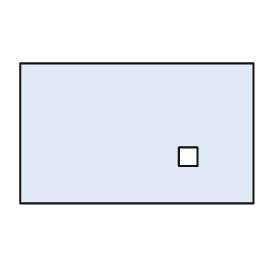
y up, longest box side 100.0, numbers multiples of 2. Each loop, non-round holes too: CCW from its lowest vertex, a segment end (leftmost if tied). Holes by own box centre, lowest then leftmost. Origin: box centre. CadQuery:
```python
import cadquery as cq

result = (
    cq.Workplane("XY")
    .moveTo(-50.0, -30.0)
    .lineTo(50.0, -30.0)
    .lineTo(50.0, 30.0)
    .lineTo(-50.0, 30.0)
    .close()
    .moveTo(18.0, -14.0)
    .lineTo(26.0, -14.0)
    .lineTo(26.0, -6.0)
    .lineTo(18.0, -6.0)
    .close()
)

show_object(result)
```